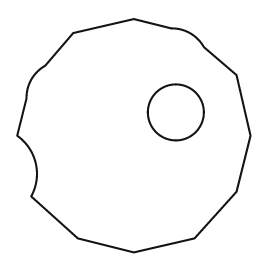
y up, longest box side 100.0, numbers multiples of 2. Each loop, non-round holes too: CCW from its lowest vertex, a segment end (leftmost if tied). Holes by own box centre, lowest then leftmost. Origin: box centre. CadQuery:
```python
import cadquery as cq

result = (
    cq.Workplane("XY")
    .moveTo(0.0, -50.0)
    .lineTo(26.0, -44.0)
    .lineTo(44.0, -24.0)
    .lineTo(50.0, 0.0)
    .lineTo(44.0, 26.0)
    .lineTo(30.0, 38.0)
    .threePointArc((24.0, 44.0), (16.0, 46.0))
    .lineTo(0.0, 50.0)
    .lineTo(-26.0, 44.0)
    .lineTo(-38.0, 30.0)
    .threePointArc((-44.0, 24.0), (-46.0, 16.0))
    .lineTo(-50.0, 0.0)
    .threePointArc((-42.0, -12.0), (-44.0, -26.0))
    .lineTo(-24.0, -44.0)
    .close()
    .moveTo(18.0, 10.0)
    .circle(12.0)
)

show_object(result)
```